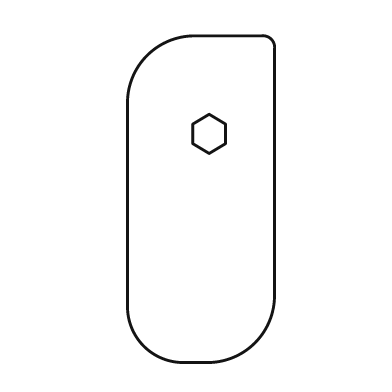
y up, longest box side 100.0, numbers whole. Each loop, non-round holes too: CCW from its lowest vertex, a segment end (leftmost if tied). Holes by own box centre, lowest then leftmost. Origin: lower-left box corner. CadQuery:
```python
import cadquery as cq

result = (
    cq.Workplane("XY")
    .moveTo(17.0, 0.0)
    .lineTo(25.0, 0.0)
    .threePointArc((39.0, 6.0), (45.0, 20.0))
    .lineTo(45.0, 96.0)
    .threePointArc((44.0, 99.0), (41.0, 100.0))
    .lineTo(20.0, 100.0)
    .threePointArc((6.0, 94.0), (0.0, 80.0))
    .lineTo(0.0, 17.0)
    .threePointArc((5.0, 5.0), (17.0, 0.0))
    .close()
    .moveTo(25.0, 64.0)
    .lineTo(30.0, 67.0)
    .lineTo(30.0, 73.0)
    .lineTo(25.0, 76.0)
    .lineTo(20.0, 73.0)
    .lineTo(20.0, 67.0)
    .close()
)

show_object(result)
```